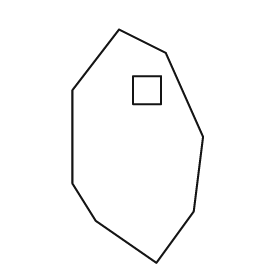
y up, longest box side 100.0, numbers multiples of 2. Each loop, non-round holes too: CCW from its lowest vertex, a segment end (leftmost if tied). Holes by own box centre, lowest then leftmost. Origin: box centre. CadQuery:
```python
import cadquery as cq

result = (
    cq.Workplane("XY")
    .moveTo(8.0, -50.0)
    .lineTo(24.0, -28.0)
    .lineTo(28.0, 4.0)
    .lineTo(12.0, 40.0)
    .lineTo(-8.0, 50.0)
    .lineTo(-28.0, 24.0)
    .lineTo(-28.0, -16.0)
    .lineTo(-18.0, -32.0)
    .close()
    .moveTo(-2.0, 18.0)
    .lineTo(10.0, 18.0)
    .lineTo(10.0, 30.0)
    .lineTo(-2.0, 30.0)
    .close()
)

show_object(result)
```